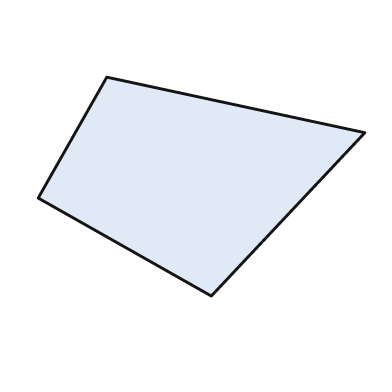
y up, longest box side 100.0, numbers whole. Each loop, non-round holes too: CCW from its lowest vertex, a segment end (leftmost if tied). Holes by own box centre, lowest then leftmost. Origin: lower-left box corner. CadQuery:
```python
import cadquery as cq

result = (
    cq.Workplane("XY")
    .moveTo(53.0, 0.0)
    .lineTo(100.0, 50.0)
    .lineTo(21.0, 67.0)
    .lineTo(0.0, 30.0)
    .close()
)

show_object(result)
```